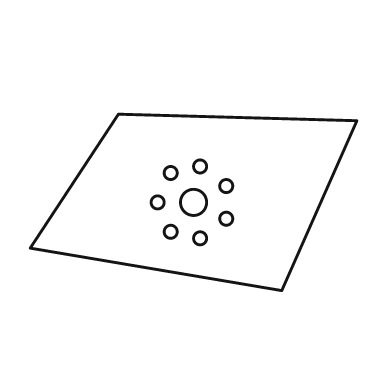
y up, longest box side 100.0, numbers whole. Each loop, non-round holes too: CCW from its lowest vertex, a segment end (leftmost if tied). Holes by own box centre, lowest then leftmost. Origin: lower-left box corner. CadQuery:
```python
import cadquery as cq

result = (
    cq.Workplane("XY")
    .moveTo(77.0, 0.0)
    .lineTo(100.0, 52.0)
    .lineTo(27.0, 54.0)
    .lineTo(0.0, 13.0)
    .close()
    .moveTo(52.0, 16.0)
    .circle(2.0)
    .moveTo(43.0, 18.0)
    .circle(2.0)
    .moveTo(60.0, 22.0)
    .circle(2.0)
    .moveTo(39.0, 27.0)
    .circle(2.0)
    .moveTo(50.0, 27.0)
    .circle(4.0)
    .moveTo(60.0, 32.0)
    .circle(2.0)
    .moveTo(43.0, 36.0)
    .circle(2.0)
    .moveTo(52.0, 38.0)
    .circle(2.0)
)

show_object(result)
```